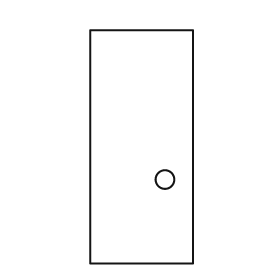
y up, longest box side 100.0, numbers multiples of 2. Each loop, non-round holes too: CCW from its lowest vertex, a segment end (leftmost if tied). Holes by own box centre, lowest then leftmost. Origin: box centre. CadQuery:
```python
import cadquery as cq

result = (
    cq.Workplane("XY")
    .moveTo(-22.0, -50.0)
    .lineTo(22.0, -50.0)
    .lineTo(22.0, 50.0)
    .lineTo(-22.0, 50.0)
    .close()
    .moveTo(10.0, -14.0)
    .circle(4.0)
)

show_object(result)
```